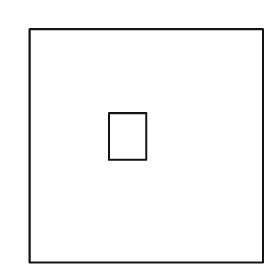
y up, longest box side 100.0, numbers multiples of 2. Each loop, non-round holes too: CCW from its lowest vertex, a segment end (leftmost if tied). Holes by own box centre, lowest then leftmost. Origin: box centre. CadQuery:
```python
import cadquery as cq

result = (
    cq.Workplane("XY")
    .moveTo(-50.0, -50.0)
    .lineTo(50.0, -50.0)
    .lineTo(50.0, 50.0)
    .lineTo(-50.0, 50.0)
    .close()
    .moveTo(-16.0, -6.0)
    .lineTo(0.0, -6.0)
    .lineTo(0.0, 14.0)
    .lineTo(-16.0, 14.0)
    .close()
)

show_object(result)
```